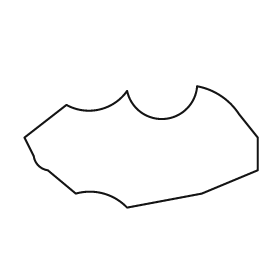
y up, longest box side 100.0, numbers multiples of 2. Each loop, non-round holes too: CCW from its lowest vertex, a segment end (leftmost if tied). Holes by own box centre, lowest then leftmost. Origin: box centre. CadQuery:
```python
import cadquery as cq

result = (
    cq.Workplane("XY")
    .moveTo(-6.0, -26.0)
    .lineTo(26.0, -20.0)
    .lineTo(50.0, -10.0)
    .lineTo(50.0, 4.0)
    .lineTo(42.0, 14.0)
    .threePointArc((34.0, 22.0), (24.0, 26.0))
    .threePointArc((10.0, 12.0), (-6.0, 24.0))
    .threePointArc((-18.0, 16.0), (-32.0, 18.0))
    .lineTo(-50.0, 4.0)
    .lineTo(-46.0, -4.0)
    .threePointArc((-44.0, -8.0), (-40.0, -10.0))
    .lineTo(-28.0, -20.0)
    .threePointArc((-16.0, -20.0), (-6.0, -26.0))
    .close()
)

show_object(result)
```